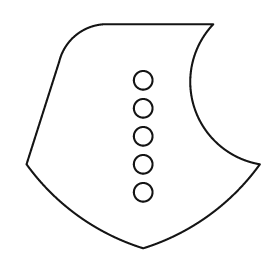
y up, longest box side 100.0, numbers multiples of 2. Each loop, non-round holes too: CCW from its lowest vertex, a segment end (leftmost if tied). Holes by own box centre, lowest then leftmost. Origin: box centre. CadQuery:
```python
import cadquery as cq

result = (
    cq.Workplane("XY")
    .moveTo(0.0, -48.0)
    .threePointArc((28.0, -34.0), (50.0, -12.0))
    .threePointArc((22.0, 12.0), (30.0, 48.0))
    .lineTo(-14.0, 48.0)
    .threePointArc((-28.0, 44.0), (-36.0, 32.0))
    .lineTo(-50.0, -12.0)
    .threePointArc((-28.0, -34.0), (0.0, -48.0))
    .close()
    .moveTo(0.0, -24.0)
    .circle(4.0)
    .moveTo(0.0, -12.0)
    .circle(4.0)
    .moveTo(0.0, 0.0)
    .circle(4.0)
    .moveTo(0.0, 12.0)
    .circle(4.0)
    .moveTo(0.0, 24.0)
    .circle(4.0)
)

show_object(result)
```